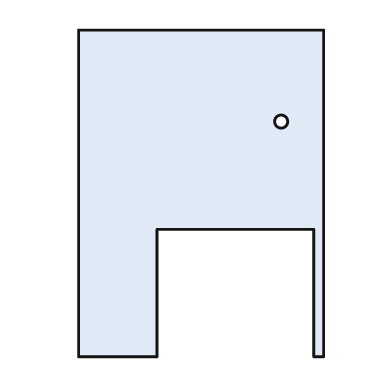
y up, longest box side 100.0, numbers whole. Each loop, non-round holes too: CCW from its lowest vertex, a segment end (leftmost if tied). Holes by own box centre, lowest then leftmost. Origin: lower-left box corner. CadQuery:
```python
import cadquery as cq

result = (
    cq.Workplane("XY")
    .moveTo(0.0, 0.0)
    .lineTo(24.0, 0.0)
    .lineTo(24.0, 39.0)
    .lineTo(72.0, 39.0)
    .lineTo(72.0, 0.0)
    .lineTo(75.0, 0.0)
    .lineTo(75.0, 100.0)
    .lineTo(0.0, 100.0)
    .close()
    .moveTo(62.0, 72.0)
    .circle(2.0)
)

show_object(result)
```